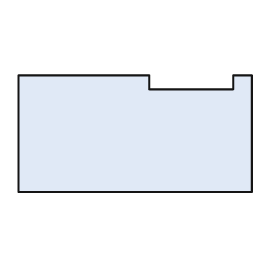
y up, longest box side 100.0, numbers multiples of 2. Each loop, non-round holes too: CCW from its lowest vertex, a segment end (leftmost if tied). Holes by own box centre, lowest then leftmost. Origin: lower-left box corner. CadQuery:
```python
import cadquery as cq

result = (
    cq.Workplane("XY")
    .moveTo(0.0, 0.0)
    .lineTo(100.0, 0.0)
    .lineTo(100.0, 50.0)
    .lineTo(92.0, 50.0)
    .lineTo(92.0, 44.0)
    .lineTo(56.0, 44.0)
    .lineTo(56.0, 50.0)
    .lineTo(0.0, 50.0)
    .close()
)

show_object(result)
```